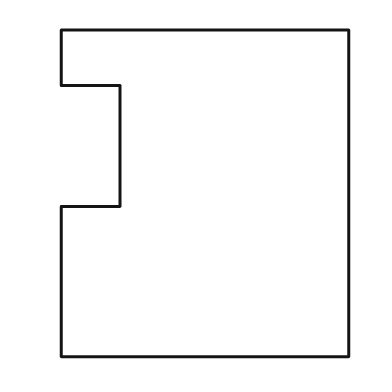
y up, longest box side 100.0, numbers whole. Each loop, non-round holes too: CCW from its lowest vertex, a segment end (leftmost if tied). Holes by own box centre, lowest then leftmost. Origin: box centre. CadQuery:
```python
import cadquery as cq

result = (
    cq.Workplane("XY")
    .moveTo(-44.0, -50.0)
    .lineTo(44.0, -50.0)
    .lineTo(44.0, 50.0)
    .lineTo(-44.0, 50.0)
    .lineTo(-44.0, 33.0)
    .lineTo(-26.0, 33.0)
    .lineTo(-26.0, -4.0)
    .lineTo(-44.0, -4.0)
    .close()
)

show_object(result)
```